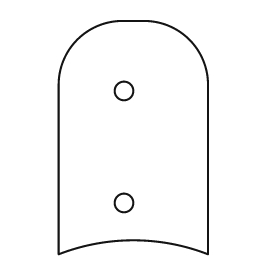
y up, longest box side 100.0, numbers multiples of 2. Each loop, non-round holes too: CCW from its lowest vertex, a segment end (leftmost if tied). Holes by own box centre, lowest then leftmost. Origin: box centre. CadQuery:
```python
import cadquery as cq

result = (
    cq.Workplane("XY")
    .moveTo(-32.0, -50.0)
    .threePointArc((0.0, -44.0), (32.0, -50.0))
    .lineTo(32.0, 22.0)
    .threePointArc((24.0, 42.0), (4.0, 50.0))
    .lineTo(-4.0, 50.0)
    .threePointArc((-24.0, 42.0), (-32.0, 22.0))
    .close()
    .moveTo(-4.0, -28.0)
    .circle(4.0)
    .moveTo(-4.0, 20.0)
    .circle(4.0)
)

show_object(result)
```